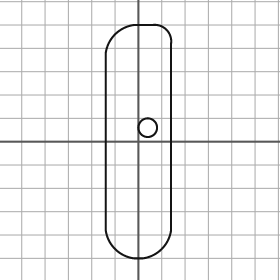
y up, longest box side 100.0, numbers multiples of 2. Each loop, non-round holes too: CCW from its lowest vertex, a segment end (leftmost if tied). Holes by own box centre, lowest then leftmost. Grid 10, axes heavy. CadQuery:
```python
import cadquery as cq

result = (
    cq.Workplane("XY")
    .moveTo(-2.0, -50.0)
    .lineTo(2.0, -50.0)
    .threePointArc((10.0, -46.0), (14.0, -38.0))
    .lineTo(14.0, 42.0)
    .threePointArc((12.0, 48.0), (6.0, 50.0))
    .lineTo(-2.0, 50.0)
    .threePointArc((-10.0, 46.0), (-14.0, 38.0))
    .lineTo(-14.0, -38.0)
    .threePointArc((-10.0, -46.0), (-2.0, -50.0))
    .close()
    .moveTo(4.0, 6.0)
    .circle(4.0)
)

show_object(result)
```